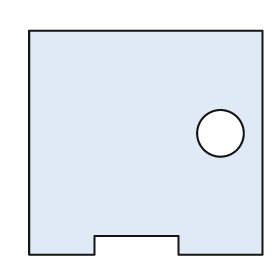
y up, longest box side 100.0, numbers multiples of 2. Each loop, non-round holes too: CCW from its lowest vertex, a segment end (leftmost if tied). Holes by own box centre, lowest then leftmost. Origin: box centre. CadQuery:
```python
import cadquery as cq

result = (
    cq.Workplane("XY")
    .moveTo(-50.0, -48.0)
    .lineTo(-22.0, -48.0)
    .lineTo(-22.0, -40.0)
    .lineTo(14.0, -40.0)
    .lineTo(14.0, -48.0)
    .lineTo(50.0, -48.0)
    .lineTo(50.0, 48.0)
    .lineTo(-50.0, 48.0)
    .close()
    .moveTo(32.0, 4.0)
    .circle(10.0)
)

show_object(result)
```